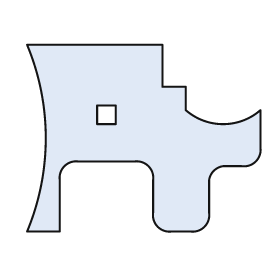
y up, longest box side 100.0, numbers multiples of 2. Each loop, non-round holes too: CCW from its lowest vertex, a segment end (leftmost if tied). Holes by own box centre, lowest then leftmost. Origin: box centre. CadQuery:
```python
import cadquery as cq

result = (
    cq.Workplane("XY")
    .moveTo(-50.0, -40.0)
    .lineTo(-36.0, -40.0)
    .lineTo(-36.0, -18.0)
    .threePointArc((-34.0, -12.0), (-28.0, -10.0))
    .lineTo(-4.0, -10.0)
    .threePointArc((2.0, -12.0), (4.0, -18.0))
    .lineTo(4.0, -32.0)
    .threePointArc((6.0, -38.0), (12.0, -40.0))
    .lineTo(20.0, -40.0)
    .threePointArc((26.0, -38.0), (28.0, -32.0))
    .lineTo(28.0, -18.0)
    .threePointArc((30.0, -14.0), (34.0, -12.0))
    .lineTo(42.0, -12.0)
    .threePointArc((48.0, -10.0), (50.0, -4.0))
    .lineTo(50.0, 12.0)
    .threePointArc((34.0, 6.0), (18.0, 12.0))
    .lineTo(18.0, 22.0)
    .lineTo(8.0, 22.0)
    .lineTo(8.0, 40.0)
    .lineTo(-50.0, 40.0)
    .threePointArc((-42.0, 0.0), (-50.0, -40.0))
    .close()
    .moveTo(-20.0, 6.0)
    .lineTo(-12.0, 6.0)
    .lineTo(-12.0, 14.0)
    .lineTo(-20.0, 14.0)
    .close()
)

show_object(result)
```